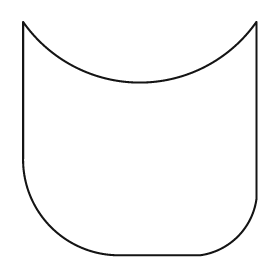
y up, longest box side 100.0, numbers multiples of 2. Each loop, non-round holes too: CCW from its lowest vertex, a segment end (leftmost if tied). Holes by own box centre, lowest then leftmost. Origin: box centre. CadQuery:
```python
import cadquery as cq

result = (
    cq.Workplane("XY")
    .moveTo(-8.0, -50.0)
    .lineTo(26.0, -50.0)
    .threePointArc((42.0, -42.0), (50.0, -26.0))
    .lineTo(50.0, 50.0)
    .threePointArc((0.0, 24.0), (-50.0, 50.0))
    .lineTo(-50.0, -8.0)
    .threePointArc((-38.0, -38.0), (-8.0, -50.0))
    .close()
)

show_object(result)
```